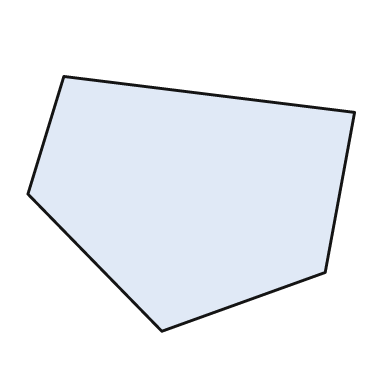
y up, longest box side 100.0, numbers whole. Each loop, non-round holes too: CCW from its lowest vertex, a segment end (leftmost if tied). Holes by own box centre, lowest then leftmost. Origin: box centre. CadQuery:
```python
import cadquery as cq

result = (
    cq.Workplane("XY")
    .moveTo(-9.0, -39.0)
    .lineTo(41.0, -21.0)
    .lineTo(50.0, 28.0)
    .lineTo(-39.0, 39.0)
    .lineTo(-50.0, 3.0)
    .close()
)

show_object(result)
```